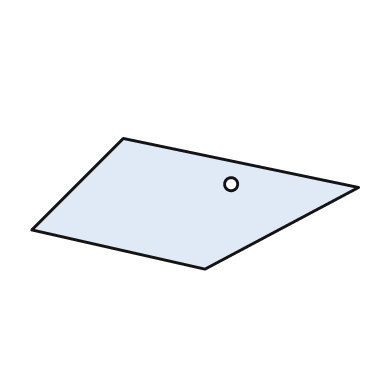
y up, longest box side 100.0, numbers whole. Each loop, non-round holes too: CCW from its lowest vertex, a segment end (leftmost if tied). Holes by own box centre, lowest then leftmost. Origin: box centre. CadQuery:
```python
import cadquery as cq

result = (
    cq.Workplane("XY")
    .moveTo(3.0, -20.0)
    .lineTo(50.0, 5.0)
    .lineTo(-22.0, 20.0)
    .lineTo(-50.0, -8.0)
    .close()
    .moveTo(11.0, 6.0)
    .circle(2.0)
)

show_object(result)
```